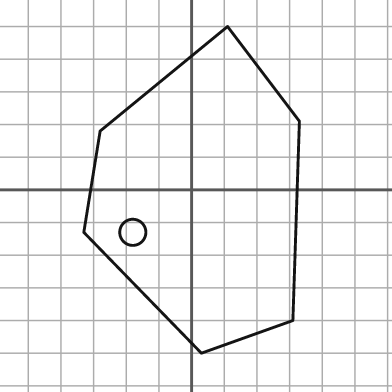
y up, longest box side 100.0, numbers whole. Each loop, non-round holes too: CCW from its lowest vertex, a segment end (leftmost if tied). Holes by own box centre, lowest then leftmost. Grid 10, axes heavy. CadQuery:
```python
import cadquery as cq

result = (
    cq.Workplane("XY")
    .moveTo(3.0, -50.0)
    .lineTo(31.0, -40.0)
    .lineTo(33.0, 21.0)
    .lineTo(11.0, 50.0)
    .lineTo(-28.0, 18.0)
    .lineTo(-33.0, -13.0)
    .close()
    .moveTo(-18.0, -13.0)
    .circle(4.0)
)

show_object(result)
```